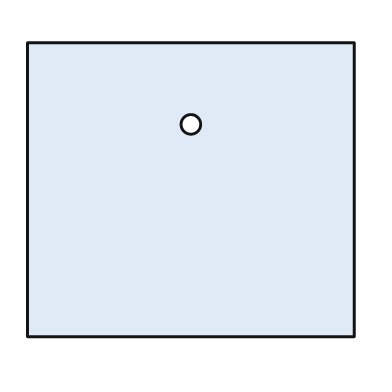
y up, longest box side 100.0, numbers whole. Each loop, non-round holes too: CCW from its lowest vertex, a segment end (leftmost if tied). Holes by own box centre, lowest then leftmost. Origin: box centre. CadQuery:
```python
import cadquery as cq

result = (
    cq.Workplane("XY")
    .moveTo(-50.0, -45.0)
    .lineTo(50.0, -45.0)
    .lineTo(50.0, 45.0)
    .lineTo(-50.0, 45.0)
    .close()
    .moveTo(0.0, 20.0)
    .circle(3.0)
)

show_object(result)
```